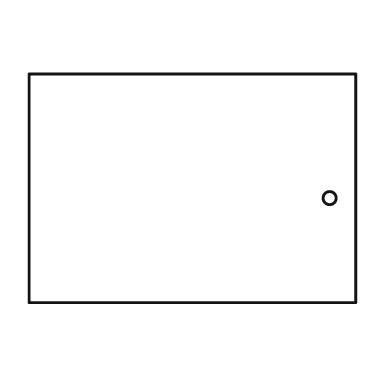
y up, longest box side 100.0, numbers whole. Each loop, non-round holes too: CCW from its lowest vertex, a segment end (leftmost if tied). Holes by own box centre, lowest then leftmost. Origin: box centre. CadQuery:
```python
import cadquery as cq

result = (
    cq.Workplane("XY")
    .moveTo(-50.0, -35.0)
    .lineTo(50.0, -35.0)
    .lineTo(50.0, 35.0)
    .lineTo(-50.0, 35.0)
    .close()
    .moveTo(42.0, -3.0)
    .circle(2.0)
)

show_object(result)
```